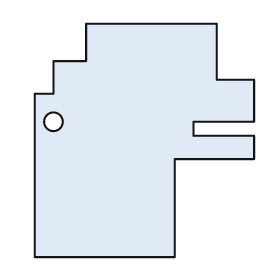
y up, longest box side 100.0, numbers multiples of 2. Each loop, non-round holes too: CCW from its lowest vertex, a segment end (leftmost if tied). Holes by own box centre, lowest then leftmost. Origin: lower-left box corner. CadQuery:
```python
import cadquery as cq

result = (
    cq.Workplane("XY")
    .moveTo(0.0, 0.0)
    .lineTo(60.0, 0.0)
    .lineTo(60.0, 42.0)
    .lineTo(94.0, 42.0)
    .lineTo(94.0, 52.0)
    .lineTo(68.0, 52.0)
    .lineTo(68.0, 58.0)
    .lineTo(94.0, 58.0)
    .lineTo(94.0, 76.0)
    .lineTo(78.0, 76.0)
    .lineTo(78.0, 100.0)
    .lineTo(22.0, 100.0)
    .lineTo(22.0, 84.0)
    .lineTo(8.0, 84.0)
    .lineTo(8.0, 70.0)
    .lineTo(0.0, 70.0)
    .close()
    .moveTo(8.0, 58.0)
    .circle(4.0)
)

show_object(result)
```